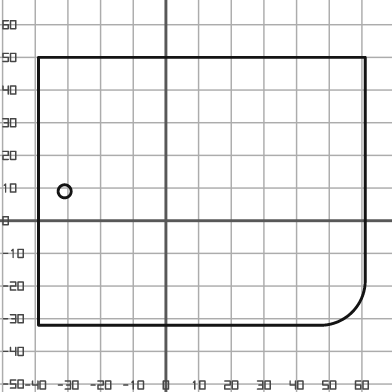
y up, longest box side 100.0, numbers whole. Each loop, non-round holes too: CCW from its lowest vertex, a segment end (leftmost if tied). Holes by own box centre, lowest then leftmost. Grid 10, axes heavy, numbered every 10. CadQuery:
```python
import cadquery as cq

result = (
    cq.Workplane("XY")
    .moveTo(-39.0, -32.0)
    .lineTo(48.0, -32.0)
    .threePointArc((57.0, -28.0), (61.0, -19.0))
    .lineTo(61.0, 50.0)
    .lineTo(-39.0, 50.0)
    .close()
    .moveTo(-31.0, 9.0)
    .circle(2.0)
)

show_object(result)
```